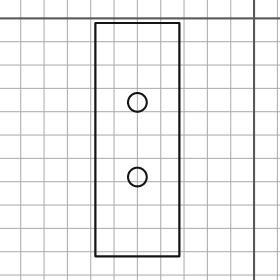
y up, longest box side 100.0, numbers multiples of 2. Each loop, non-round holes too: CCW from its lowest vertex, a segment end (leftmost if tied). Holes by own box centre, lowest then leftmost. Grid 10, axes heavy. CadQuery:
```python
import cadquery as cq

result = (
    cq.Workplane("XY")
    .moveTo(-68.0, -102.0)
    .lineTo(-32.0, -102.0)
    .lineTo(-32.0, -2.0)
    .lineTo(-68.0, -2.0)
    .close()
    .moveTo(-50.0, -68.0)
    .circle(4.0)
    .moveTo(-50.0, -36.0)
    .circle(4.0)
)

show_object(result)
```